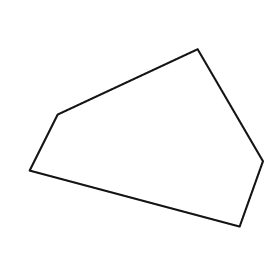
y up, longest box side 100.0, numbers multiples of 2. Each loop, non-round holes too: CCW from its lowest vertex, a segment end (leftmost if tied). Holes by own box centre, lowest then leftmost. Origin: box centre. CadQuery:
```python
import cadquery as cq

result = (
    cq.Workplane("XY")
    .moveTo(40.0, -38.0)
    .lineTo(50.0, -10.0)
    .lineTo(22.0, 38.0)
    .lineTo(-38.0, 10.0)
    .lineTo(-50.0, -14.0)
    .close()
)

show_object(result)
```